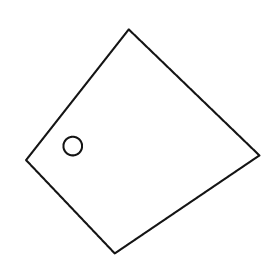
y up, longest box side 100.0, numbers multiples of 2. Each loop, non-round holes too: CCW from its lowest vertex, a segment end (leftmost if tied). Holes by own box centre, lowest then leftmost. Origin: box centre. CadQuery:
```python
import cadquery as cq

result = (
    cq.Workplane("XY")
    .moveTo(-12.0, -48.0)
    .lineTo(50.0, -6.0)
    .lineTo(-6.0, 48.0)
    .lineTo(-50.0, -8.0)
    .close()
    .moveTo(-30.0, -2.0)
    .circle(4.0)
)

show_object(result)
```